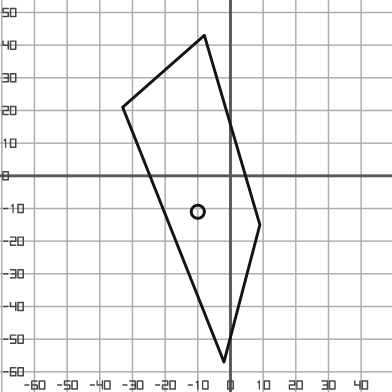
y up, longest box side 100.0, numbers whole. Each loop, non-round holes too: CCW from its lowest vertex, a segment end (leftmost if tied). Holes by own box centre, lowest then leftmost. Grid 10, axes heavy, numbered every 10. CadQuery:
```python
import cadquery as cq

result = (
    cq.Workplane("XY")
    .moveTo(-2.0, -57.0)
    .lineTo(9.0, -15.0)
    .lineTo(-8.0, 43.0)
    .lineTo(-33.0, 21.0)
    .close()
    .moveTo(-10.0, -11.0)
    .circle(2.0)
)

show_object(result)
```